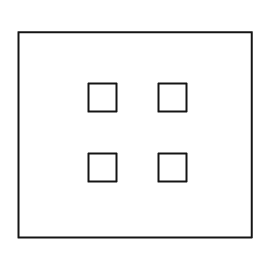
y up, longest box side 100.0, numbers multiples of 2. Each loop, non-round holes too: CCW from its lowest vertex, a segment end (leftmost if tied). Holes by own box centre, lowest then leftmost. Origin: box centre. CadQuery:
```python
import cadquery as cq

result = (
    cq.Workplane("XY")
    .moveTo(-50.0, -44.0)
    .lineTo(50.0, -44.0)
    .lineTo(50.0, 44.0)
    .lineTo(-50.0, 44.0)
    .close()
    .moveTo(-20.0, -20.0)
    .lineTo(-8.0, -20.0)
    .lineTo(-8.0, -8.0)
    .lineTo(-20.0, -8.0)
    .close()
    .moveTo(10.0, -20.0)
    .lineTo(22.0, -20.0)
    .lineTo(22.0, -8.0)
    .lineTo(10.0, -8.0)
    .close()
    .moveTo(-20.0, 10.0)
    .lineTo(-8.0, 10.0)
    .lineTo(-8.0, 22.0)
    .lineTo(-20.0, 22.0)
    .close()
    .moveTo(10.0, 10.0)
    .lineTo(22.0, 10.0)
    .lineTo(22.0, 22.0)
    .lineTo(10.0, 22.0)
    .close()
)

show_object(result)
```